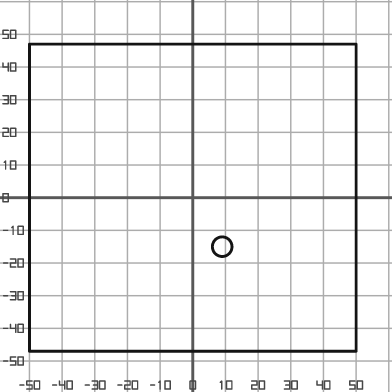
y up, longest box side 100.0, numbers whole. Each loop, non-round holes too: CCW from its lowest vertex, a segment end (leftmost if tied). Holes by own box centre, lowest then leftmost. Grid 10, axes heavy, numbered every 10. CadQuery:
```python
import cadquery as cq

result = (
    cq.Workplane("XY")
    .moveTo(-50.0, -47.0)
    .lineTo(50.0, -47.0)
    .lineTo(50.0, 47.0)
    .lineTo(-50.0, 47.0)
    .close()
    .moveTo(9.0, -15.0)
    .circle(3.0)
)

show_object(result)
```